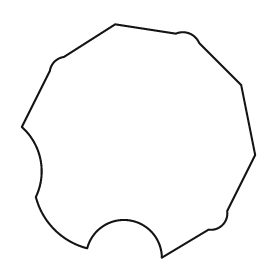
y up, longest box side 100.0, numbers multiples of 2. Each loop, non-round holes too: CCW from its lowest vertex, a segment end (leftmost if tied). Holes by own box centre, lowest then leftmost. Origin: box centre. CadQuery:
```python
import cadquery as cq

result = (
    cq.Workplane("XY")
    .moveTo(10.0, -50.0)
    .lineTo(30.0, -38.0)
    .threePointArc((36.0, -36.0), (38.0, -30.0))
    .lineTo(50.0, -6.0)
    .lineTo(44.0, 24.0)
    .lineTo(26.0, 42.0)
    .threePointArc((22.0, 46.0), (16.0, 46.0))
    .lineTo(-10.0, 50.0)
    .lineTo(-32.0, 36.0)
    .threePointArc((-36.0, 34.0), (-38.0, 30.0))
    .lineTo(-50.0, 6.0)
    .threePointArc((-42.0, -8.0), (-44.0, -24.0))
    .threePointArc((-36.0, -38.0), (-22.0, -46.0))
    .threePointArc((-4.0, -34.0), (10.0, -50.0))
    .close()
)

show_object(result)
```